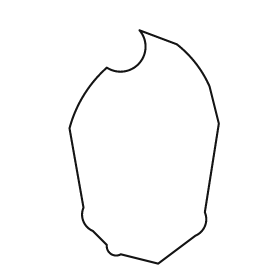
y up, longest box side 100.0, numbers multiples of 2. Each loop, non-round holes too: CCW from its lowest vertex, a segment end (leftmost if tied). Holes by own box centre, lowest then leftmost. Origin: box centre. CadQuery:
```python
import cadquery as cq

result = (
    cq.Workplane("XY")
    .moveTo(6.0, -50.0)
    .lineTo(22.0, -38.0)
    .threePointArc((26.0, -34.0), (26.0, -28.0))
    .lineTo(32.0, 10.0)
    .lineTo(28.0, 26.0)
    .threePointArc((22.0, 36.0), (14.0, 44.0))
    .lineTo(-2.0, 50.0)
    .threePointArc((-2.0, 36.0), (-16.0, 34.0))
    .threePointArc((-26.0, 22.0), (-32.0, 8.0))
    .lineTo(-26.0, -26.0)
    .threePointArc((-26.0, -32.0), (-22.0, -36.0))
    .lineTo(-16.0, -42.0)
    .threePointArc((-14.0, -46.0), (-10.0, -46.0))
    .close()
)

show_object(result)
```